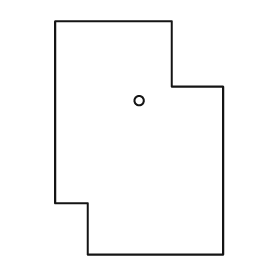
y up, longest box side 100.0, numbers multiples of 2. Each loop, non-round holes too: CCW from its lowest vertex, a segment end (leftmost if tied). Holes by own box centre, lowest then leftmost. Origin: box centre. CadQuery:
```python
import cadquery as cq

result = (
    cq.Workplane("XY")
    .moveTo(-22.0, -50.0)
    .lineTo(36.0, -50.0)
    .lineTo(36.0, 22.0)
    .lineTo(14.0, 22.0)
    .lineTo(14.0, 50.0)
    .lineTo(-36.0, 50.0)
    .lineTo(-36.0, -28.0)
    .lineTo(-22.0, -28.0)
    .close()
    .moveTo(0.0, 16.0)
    .circle(2.0)
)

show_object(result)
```